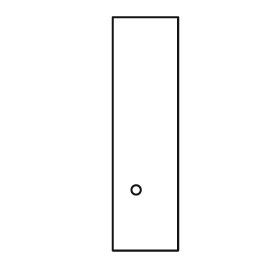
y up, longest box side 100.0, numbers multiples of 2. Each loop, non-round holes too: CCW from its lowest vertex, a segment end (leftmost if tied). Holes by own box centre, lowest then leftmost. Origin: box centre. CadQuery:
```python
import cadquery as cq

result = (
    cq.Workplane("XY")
    .moveTo(-14.0, -50.0)
    .lineTo(14.0, -50.0)
    .lineTo(14.0, 50.0)
    .lineTo(-14.0, 50.0)
    .close()
    .moveTo(-4.0, -24.0)
    .circle(2.0)
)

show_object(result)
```